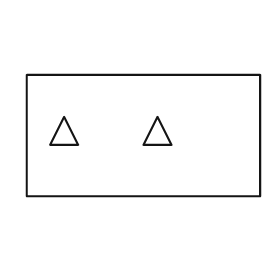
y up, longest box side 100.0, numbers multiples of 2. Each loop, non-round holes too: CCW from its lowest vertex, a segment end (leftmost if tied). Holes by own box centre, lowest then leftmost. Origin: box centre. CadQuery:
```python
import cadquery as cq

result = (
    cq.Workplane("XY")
    .moveTo(-50.0, -26.0)
    .lineTo(50.0, -26.0)
    .lineTo(50.0, 26.0)
    .lineTo(-50.0, 26.0)
    .close()
    .moveTo(-40.0, -4.0)
    .lineTo(-28.0, -4.0)
    .lineTo(-34.0, 8.0)
    .close()
    .moveTo(0.0, -4.0)
    .lineTo(12.0, -4.0)
    .lineTo(6.0, 8.0)
    .close()
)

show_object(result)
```